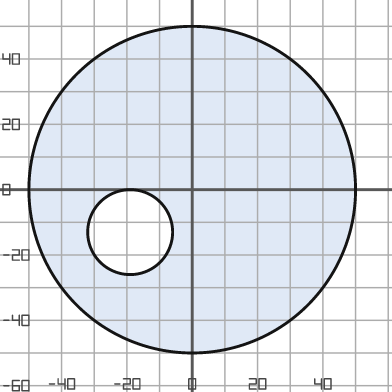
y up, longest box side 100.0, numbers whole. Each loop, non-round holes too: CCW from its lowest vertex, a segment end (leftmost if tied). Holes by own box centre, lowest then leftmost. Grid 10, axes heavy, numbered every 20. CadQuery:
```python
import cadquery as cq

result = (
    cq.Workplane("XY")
    .moveTo(0.0, 0.0)
    .circle(50.0)
    .moveTo(-19.0, -13.0)
    .circle(13.0)
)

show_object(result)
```